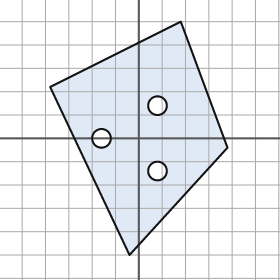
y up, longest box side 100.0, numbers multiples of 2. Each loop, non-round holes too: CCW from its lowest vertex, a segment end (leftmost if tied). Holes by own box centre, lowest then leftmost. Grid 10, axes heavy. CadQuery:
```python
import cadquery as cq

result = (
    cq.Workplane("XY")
    .moveTo(-4.0, -50.0)
    .lineTo(38.0, -4.0)
    .lineTo(18.0, 50.0)
    .lineTo(-38.0, 22.0)
    .close()
    .moveTo(8.0, -14.0)
    .circle(4.0)
    .moveTo(-16.0, 0.0)
    .circle(4.0)
    .moveTo(8.0, 14.0)
    .circle(4.0)
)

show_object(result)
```